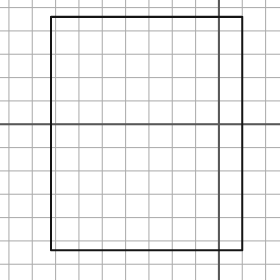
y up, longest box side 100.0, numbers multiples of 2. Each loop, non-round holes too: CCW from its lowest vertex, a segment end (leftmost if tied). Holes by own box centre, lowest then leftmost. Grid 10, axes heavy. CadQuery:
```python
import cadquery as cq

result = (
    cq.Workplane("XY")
    .moveTo(-72.0, -54.0)
    .lineTo(10.0, -54.0)
    .lineTo(10.0, 46.0)
    .lineTo(-72.0, 46.0)
    .close()
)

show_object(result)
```